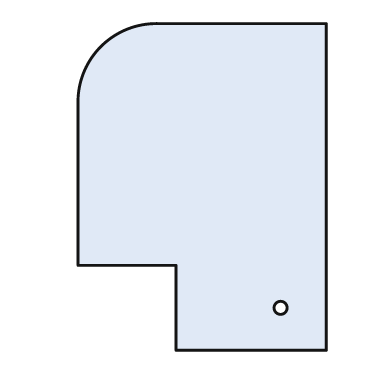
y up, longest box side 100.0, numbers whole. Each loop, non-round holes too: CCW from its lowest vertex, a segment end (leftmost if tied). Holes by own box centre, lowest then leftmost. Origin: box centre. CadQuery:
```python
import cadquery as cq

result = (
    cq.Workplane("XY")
    .moveTo(-8.0, -50.0)
    .lineTo(38.0, -50.0)
    .lineTo(38.0, 50.0)
    .lineTo(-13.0, 50.0)
    .threePointArc((-31.0, 43.0), (-38.0, 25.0))
    .lineTo(-38.0, -24.0)
    .lineTo(-8.0, -24.0)
    .close()
    .moveTo(24.0, -37.0)
    .circle(2.0)
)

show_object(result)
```